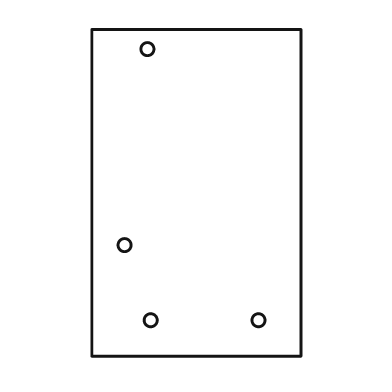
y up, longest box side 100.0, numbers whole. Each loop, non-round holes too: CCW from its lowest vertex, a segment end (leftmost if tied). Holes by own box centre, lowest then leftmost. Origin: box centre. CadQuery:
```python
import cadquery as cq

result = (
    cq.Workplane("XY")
    .moveTo(-32.0, -50.0)
    .lineTo(32.0, -50.0)
    .lineTo(32.0, 50.0)
    .lineTo(-32.0, 50.0)
    .close()
    .moveTo(-14.0, -39.0)
    .circle(2.0)
    .moveTo(19.0, -39.0)
    .circle(2.0)
    .moveTo(-22.0, -16.0)
    .circle(2.0)
    .moveTo(-15.0, 44.0)
    .circle(2.0)
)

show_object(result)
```